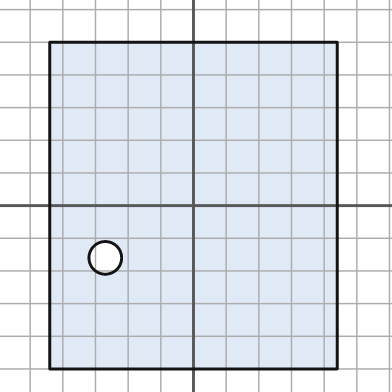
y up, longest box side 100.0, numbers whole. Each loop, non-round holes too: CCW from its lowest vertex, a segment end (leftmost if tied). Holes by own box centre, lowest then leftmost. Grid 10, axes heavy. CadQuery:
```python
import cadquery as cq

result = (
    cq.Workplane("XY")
    .moveTo(-44.0, -50.0)
    .lineTo(44.0, -50.0)
    .lineTo(44.0, 50.0)
    .lineTo(-44.0, 50.0)
    .close()
    .moveTo(-27.0, -16.0)
    .circle(5.0)
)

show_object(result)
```